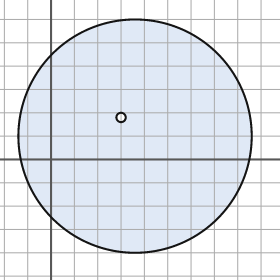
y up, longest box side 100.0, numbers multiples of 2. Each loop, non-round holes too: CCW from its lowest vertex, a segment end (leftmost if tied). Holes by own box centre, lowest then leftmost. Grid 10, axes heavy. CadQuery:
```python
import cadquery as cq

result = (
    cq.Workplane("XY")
    .moveTo(36.0, 10.0)
    .circle(50.0)
    .moveTo(30.0, 18.0)
    .circle(2.0)
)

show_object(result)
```